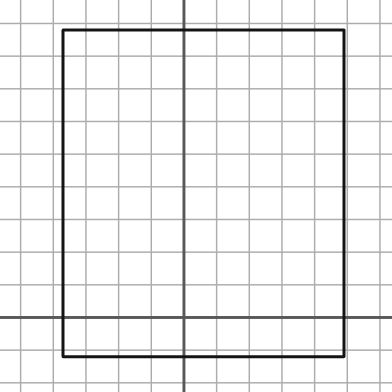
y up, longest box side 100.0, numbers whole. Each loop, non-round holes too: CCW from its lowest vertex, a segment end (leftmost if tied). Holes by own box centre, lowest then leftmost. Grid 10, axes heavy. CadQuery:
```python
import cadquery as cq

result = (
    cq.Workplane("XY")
    .moveTo(-37.0, -12.0)
    .lineTo(49.0, -12.0)
    .lineTo(49.0, 88.0)
    .lineTo(-37.0, 88.0)
    .close()
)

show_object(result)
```